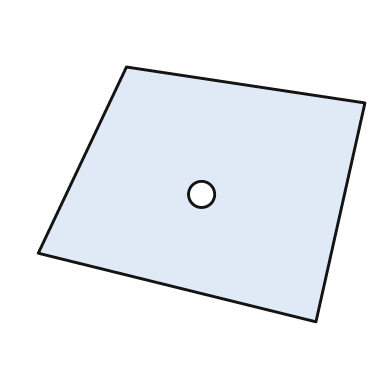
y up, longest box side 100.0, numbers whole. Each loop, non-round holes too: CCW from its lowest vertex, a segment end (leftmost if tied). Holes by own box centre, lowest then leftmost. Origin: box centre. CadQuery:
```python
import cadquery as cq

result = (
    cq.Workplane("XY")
    .moveTo(35.0, -39.0)
    .lineTo(50.0, 28.0)
    .lineTo(-23.0, 39.0)
    .lineTo(-50.0, -18.0)
    .close()
    .moveTo(0.0, 0.0)
    .circle(4.0)
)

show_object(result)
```